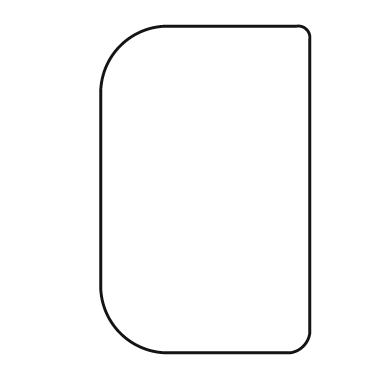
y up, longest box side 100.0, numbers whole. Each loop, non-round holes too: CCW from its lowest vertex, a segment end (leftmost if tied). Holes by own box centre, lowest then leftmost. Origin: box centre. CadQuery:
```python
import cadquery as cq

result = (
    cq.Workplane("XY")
    .moveTo(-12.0, -50.0)
    .lineTo(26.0, -50.0)
    .threePointArc((30.0, -48.0), (32.0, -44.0))
    .lineTo(32.0, 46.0)
    .threePointArc((31.0, 49.0), (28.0, 50.0))
    .lineTo(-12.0, 50.0)
    .threePointArc((-26.0, 44.0), (-32.0, 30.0))
    .lineTo(-32.0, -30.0)
    .threePointArc((-26.0, -44.0), (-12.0, -50.0))
    .close()
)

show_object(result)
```